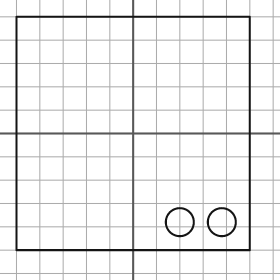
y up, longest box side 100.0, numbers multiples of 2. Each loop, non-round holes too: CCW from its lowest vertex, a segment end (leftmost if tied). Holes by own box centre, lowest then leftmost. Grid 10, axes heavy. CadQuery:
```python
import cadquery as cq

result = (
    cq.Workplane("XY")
    .moveTo(-50.0, -50.0)
    .lineTo(50.0, -50.0)
    .lineTo(50.0, 50.0)
    .lineTo(-50.0, 50.0)
    .close()
    .moveTo(20.0, -38.0)
    .circle(6.0)
    .moveTo(38.0, -38.0)
    .circle(6.0)
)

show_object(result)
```